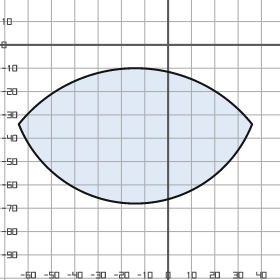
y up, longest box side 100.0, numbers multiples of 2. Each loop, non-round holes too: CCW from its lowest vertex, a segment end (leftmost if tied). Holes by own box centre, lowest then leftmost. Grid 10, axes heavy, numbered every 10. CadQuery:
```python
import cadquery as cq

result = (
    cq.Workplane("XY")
    .moveTo(-64.0, -34.0)
    .threePointArc((-14.0, -68.0), (36.0, -34.0))
    .threePointArc((-14.0, -10.0), (-64.0, -34.0))
    .close()
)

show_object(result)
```